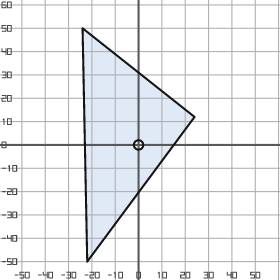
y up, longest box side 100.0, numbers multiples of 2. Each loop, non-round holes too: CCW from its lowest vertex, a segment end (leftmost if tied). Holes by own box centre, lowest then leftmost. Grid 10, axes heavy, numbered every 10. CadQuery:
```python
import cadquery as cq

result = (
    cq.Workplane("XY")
    .moveTo(-22.0, -50.0)
    .lineTo(24.0, 12.0)
    .lineTo(-24.0, 50.0)
    .close()
    .moveTo(0.0, 0.0)
    .circle(2.0)
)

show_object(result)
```